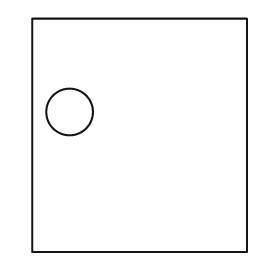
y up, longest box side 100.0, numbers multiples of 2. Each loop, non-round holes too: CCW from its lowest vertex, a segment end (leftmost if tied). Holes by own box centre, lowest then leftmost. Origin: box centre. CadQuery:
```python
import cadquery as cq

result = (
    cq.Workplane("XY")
    .moveTo(-46.0, -50.0)
    .lineTo(46.0, -50.0)
    .lineTo(46.0, 50.0)
    .lineTo(-46.0, 50.0)
    .close()
    .moveTo(-30.0, 10.0)
    .circle(10.0)
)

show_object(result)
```